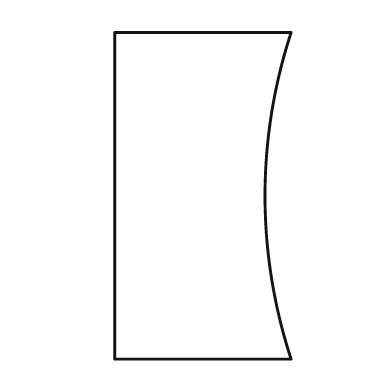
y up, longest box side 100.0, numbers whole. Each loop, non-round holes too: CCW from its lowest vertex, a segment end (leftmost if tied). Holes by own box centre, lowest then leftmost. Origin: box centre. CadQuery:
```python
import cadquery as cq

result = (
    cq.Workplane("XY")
    .moveTo(-27.0, -50.0)
    .lineTo(27.0, -50.0)
    .threePointArc((19.0, 0.0), (27.0, 50.0))
    .lineTo(-27.0, 50.0)
    .close()
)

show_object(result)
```